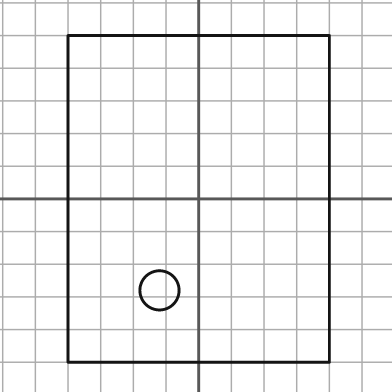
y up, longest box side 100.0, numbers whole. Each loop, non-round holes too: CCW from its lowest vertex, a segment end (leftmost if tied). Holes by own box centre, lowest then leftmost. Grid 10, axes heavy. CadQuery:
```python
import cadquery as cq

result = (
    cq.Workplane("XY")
    .moveTo(-40.0, -50.0)
    .lineTo(40.0, -50.0)
    .lineTo(40.0, 50.0)
    .lineTo(-40.0, 50.0)
    .close()
    .moveTo(-12.0, -28.0)
    .circle(6.0)
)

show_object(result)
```